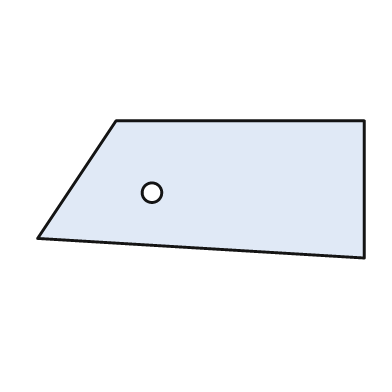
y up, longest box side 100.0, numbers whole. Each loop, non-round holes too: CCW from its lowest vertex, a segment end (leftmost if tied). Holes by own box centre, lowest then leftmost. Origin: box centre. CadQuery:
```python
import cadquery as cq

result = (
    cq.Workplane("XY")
    .moveTo(50.0, -21.0)
    .lineTo(50.0, 21.0)
    .lineTo(-26.0, 21.0)
    .lineTo(-50.0, -15.0)
    .close()
    .moveTo(-15.0, -1.0)
    .circle(3.0)
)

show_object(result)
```